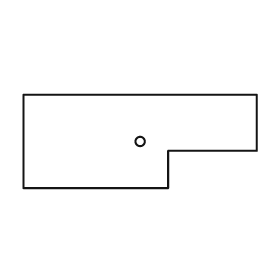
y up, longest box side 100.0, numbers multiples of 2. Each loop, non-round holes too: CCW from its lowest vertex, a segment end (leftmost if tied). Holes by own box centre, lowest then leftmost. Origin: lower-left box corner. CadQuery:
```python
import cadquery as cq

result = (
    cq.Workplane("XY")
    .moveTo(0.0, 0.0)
    .lineTo(62.0, 0.0)
    .lineTo(62.0, 16.0)
    .lineTo(100.0, 16.0)
    .lineTo(100.0, 40.0)
    .lineTo(0.0, 40.0)
    .close()
    .moveTo(50.0, 20.0)
    .circle(2.0)
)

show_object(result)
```